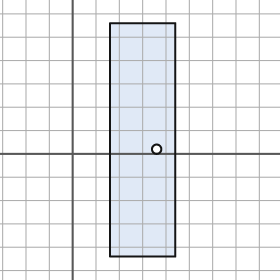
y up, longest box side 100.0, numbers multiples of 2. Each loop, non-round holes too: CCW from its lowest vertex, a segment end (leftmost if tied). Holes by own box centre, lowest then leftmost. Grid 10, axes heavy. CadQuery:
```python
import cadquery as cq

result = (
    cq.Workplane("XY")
    .moveTo(16.0, -44.0)
    .lineTo(44.0, -44.0)
    .lineTo(44.0, 56.0)
    .lineTo(16.0, 56.0)
    .close()
    .moveTo(36.0, 2.0)
    .circle(2.0)
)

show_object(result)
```